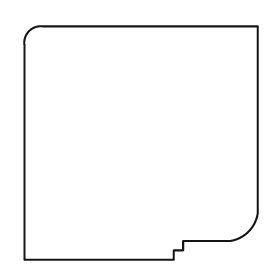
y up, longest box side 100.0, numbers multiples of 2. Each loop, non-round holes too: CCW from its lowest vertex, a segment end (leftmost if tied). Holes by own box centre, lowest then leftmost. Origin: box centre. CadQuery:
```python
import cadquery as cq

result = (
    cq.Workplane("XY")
    .moveTo(-50.0, -50.0)
    .lineTo(14.0, -50.0)
    .lineTo(14.0, -46.0)
    .lineTo(18.0, -46.0)
    .lineTo(18.0, -42.0)
    .lineTo(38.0, -42.0)
    .threePointArc((46.0, -38.0), (50.0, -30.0))
    .lineTo(50.0, 50.0)
    .lineTo(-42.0, 50.0)
    .threePointArc((-48.0, 48.0), (-50.0, 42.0))
    .close()
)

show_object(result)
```